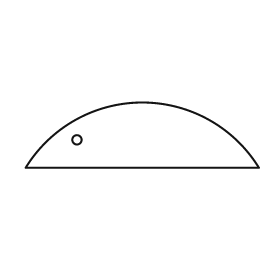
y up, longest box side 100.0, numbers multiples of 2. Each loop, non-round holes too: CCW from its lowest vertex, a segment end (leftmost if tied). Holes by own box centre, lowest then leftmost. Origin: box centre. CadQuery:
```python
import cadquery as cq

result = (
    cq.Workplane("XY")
    .moveTo(-50.0, -14.0)
    .lineTo(50.0, -14.0)
    .threePointArc((0.0, 14.0), (-50.0, -14.0))
    .close()
    .moveTo(-28.0, -2.0)
    .circle(2.0)
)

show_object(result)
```